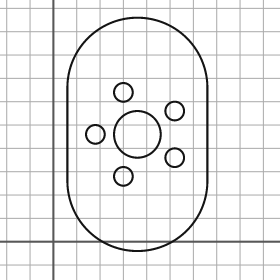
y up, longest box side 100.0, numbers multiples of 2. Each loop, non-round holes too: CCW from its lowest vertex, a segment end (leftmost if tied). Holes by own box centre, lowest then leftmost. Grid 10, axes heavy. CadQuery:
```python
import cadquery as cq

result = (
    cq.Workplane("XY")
    .moveTo(6.0, 26.0)
    .threePointArc((36.0, -4.0), (66.0, 26.0))
    .lineTo(66.0, 66.0)
    .threePointArc((36.0, 96.0), (6.0, 66.0))
    .close()
    .moveTo(30.0, 28.0)
    .circle(4.0)
    .moveTo(52.0, 36.0)
    .circle(4.0)
    .moveTo(18.0, 46.0)
    .circle(4.0)
    .moveTo(36.0, 46.0)
    .circle(10.0)
    .moveTo(52.0, 56.0)
    .circle(4.0)
    .moveTo(30.0, 64.0)
    .circle(4.0)
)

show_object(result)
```